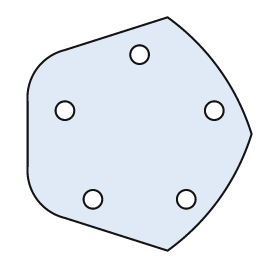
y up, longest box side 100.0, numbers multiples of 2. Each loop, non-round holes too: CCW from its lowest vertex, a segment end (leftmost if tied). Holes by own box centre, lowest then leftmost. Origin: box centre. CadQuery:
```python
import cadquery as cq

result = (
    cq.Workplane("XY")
    .moveTo(12.0, -50.0)
    .threePointArc((34.0, -28.0), (48.0, 0.0))
    .threePointArc((34.0, 28.0), (12.0, 50.0))
    .lineTo(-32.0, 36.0)
    .threePointArc((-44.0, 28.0), (-48.0, 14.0))
    .lineTo(-48.0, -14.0)
    .threePointArc((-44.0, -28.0), (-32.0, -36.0))
    .close()
    .moveTo(-20.0, -28.0)
    .circle(4.0)
    .moveTo(20.0, -28.0)
    .circle(4.0)
    .moveTo(-32.0, 10.0)
    .circle(4.0)
    .moveTo(32.0, 10.0)
    .circle(4.0)
    .moveTo(0.0, 34.0)
    .circle(4.0)
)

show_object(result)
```